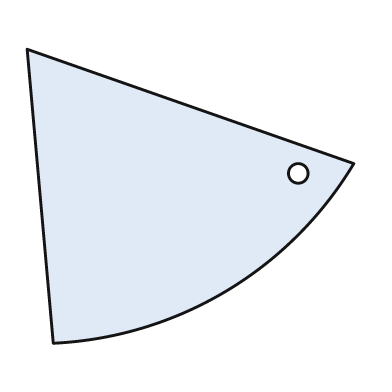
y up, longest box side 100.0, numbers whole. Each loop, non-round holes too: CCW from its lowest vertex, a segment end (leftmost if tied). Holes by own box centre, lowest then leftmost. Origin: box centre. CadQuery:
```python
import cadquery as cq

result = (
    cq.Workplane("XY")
    .moveTo(-42.0, -45.0)
    .threePointArc((11.0, -29.0), (50.0, 10.0))
    .lineTo(-50.0, 45.0)
    .close()
    .moveTo(33.0, 7.0)
    .circle(3.0)
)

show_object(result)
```